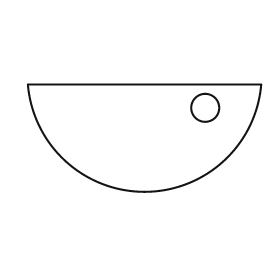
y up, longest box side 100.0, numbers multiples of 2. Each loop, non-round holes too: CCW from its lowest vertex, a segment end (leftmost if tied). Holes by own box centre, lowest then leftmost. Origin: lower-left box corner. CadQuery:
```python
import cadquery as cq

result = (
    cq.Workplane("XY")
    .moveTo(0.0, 46.0)
    .threePointArc((50.0, 0.0), (100.0, 46.0))
    .close()
    .moveTo(76.0, 36.0)
    .circle(6.0)
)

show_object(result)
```